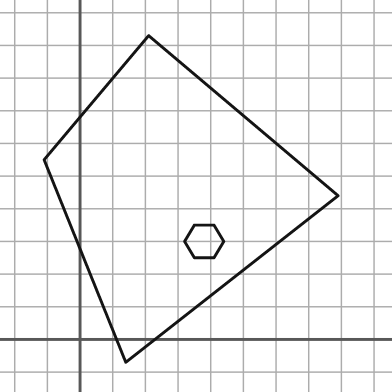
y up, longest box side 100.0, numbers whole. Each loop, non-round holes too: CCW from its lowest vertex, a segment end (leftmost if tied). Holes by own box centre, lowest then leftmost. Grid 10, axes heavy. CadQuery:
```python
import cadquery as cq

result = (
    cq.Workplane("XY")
    .moveTo(14.0, -7.0)
    .lineTo(79.0, 44.0)
    .lineTo(21.0, 93.0)
    .lineTo(-11.0, 55.0)
    .close()
    .moveTo(35.0, 25.0)
    .lineTo(41.0, 25.0)
    .lineTo(44.0, 30.0)
    .lineTo(41.0, 35.0)
    .lineTo(35.0, 35.0)
    .lineTo(32.0, 30.0)
    .close()
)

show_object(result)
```